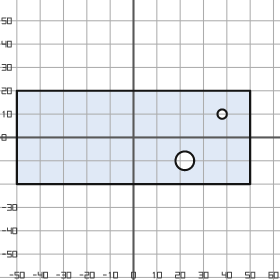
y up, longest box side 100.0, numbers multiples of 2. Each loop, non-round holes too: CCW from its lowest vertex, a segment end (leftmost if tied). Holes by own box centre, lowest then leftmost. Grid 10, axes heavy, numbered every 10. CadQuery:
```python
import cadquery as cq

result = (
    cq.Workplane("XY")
    .moveTo(-50.0, -20.0)
    .lineTo(50.0, -20.0)
    .lineTo(50.0, 20.0)
    .lineTo(-50.0, 20.0)
    .close()
    .moveTo(22.0, -10.0)
    .circle(4.0)
    .moveTo(38.0, 10.0)
    .circle(2.0)
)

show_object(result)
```